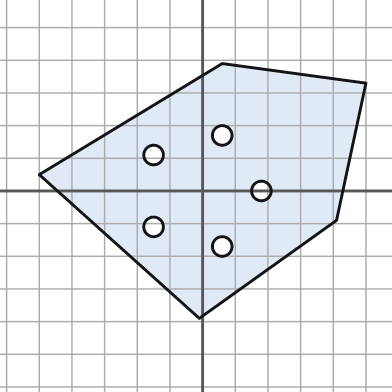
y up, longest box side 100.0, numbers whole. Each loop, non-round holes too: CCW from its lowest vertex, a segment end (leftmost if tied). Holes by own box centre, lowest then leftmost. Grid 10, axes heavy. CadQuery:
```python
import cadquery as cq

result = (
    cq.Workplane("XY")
    .moveTo(-1.0, -39.0)
    .lineTo(41.0, -9.0)
    .lineTo(50.0, 33.0)
    .lineTo(6.0, 39.0)
    .lineTo(-50.0, 5.0)
    .close()
    .moveTo(6.0, -17.0)
    .circle(3.0)
    .moveTo(-15.0, -11.0)
    .circle(3.0)
    .moveTo(18.0, 0.0)
    .circle(3.0)
    .moveTo(-15.0, 11.0)
    .circle(3.0)
    .moveTo(6.0, 17.0)
    .circle(3.0)
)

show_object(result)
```